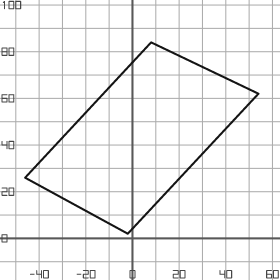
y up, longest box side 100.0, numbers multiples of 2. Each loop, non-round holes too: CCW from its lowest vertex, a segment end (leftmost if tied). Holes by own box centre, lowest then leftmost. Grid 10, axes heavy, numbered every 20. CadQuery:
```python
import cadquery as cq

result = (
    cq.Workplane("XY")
    .moveTo(-2.0, 2.0)
    .lineTo(54.0, 62.0)
    .lineTo(8.0, 84.0)
    .lineTo(-46.0, 26.0)
    .close()
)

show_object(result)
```